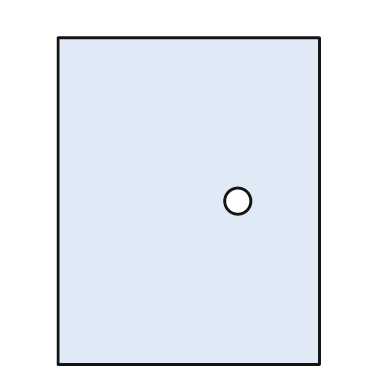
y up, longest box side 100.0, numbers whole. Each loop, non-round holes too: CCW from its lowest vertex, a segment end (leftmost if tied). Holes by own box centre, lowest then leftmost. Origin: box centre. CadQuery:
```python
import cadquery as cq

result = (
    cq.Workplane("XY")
    .moveTo(-40.0, -50.0)
    .lineTo(40.0, -50.0)
    .lineTo(40.0, 50.0)
    .lineTo(-40.0, 50.0)
    .close()
    .moveTo(15.0, 0.0)
    .circle(4.0)
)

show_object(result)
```